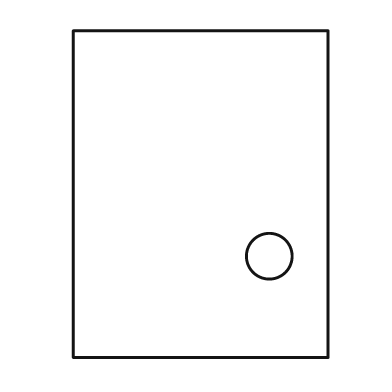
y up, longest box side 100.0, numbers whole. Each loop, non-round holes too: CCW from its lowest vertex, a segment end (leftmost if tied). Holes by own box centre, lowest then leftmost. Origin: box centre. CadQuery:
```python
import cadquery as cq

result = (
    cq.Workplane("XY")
    .moveTo(-39.0, -50.0)
    .lineTo(39.0, -50.0)
    .lineTo(39.0, 50.0)
    .lineTo(-39.0, 50.0)
    .close()
    .moveTo(21.0, -19.0)
    .circle(7.0)
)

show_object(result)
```